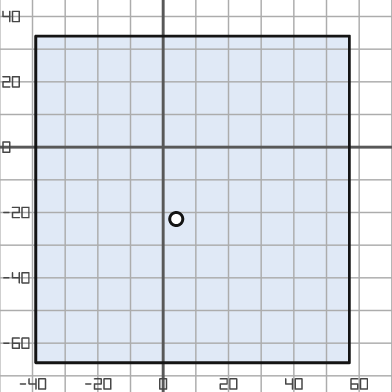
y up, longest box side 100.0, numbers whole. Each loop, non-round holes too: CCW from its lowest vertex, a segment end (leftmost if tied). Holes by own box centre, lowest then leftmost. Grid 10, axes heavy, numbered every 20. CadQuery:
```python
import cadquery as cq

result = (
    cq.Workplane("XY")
    .moveTo(-39.0, -66.0)
    .lineTo(57.0, -66.0)
    .lineTo(57.0, 34.0)
    .lineTo(-39.0, 34.0)
    .close()
    .moveTo(4.0, -22.0)
    .circle(2.0)
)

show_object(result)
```